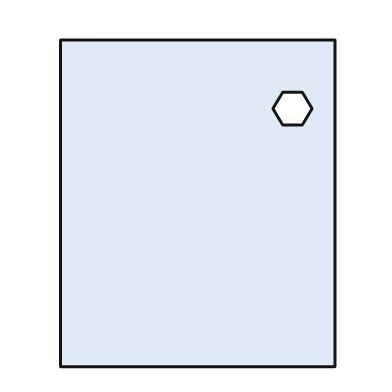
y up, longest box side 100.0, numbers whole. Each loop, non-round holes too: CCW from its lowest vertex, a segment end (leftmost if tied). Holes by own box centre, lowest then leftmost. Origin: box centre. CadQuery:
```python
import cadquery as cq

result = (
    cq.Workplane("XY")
    .moveTo(-42.0, -50.0)
    .lineTo(42.0, -50.0)
    .lineTo(42.0, 50.0)
    .lineTo(-42.0, 50.0)
    .close()
    .moveTo(26.0, 24.0)
    .lineTo(32.0, 24.0)
    .lineTo(35.0, 29.0)
    .lineTo(32.0, 34.0)
    .lineTo(26.0, 34.0)
    .lineTo(23.0, 29.0)
    .close()
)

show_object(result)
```